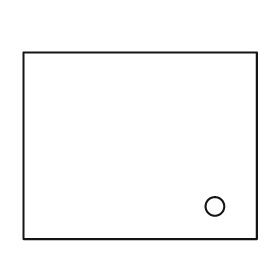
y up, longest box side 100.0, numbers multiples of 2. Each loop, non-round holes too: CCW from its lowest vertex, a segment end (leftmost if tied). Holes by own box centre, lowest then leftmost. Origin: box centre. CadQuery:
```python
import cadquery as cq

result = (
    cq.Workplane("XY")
    .moveTo(-50.0, -40.0)
    .lineTo(50.0, -40.0)
    .lineTo(50.0, 40.0)
    .lineTo(-50.0, 40.0)
    .close()
    .moveTo(32.0, -26.0)
    .circle(4.0)
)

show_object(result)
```